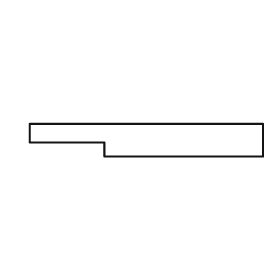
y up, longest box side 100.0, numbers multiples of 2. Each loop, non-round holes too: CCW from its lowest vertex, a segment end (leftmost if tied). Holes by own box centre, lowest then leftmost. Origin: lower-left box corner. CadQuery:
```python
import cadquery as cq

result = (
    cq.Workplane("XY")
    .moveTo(32.0, 0.0)
    .lineTo(100.0, 0.0)
    .lineTo(100.0, 14.0)
    .lineTo(0.0, 14.0)
    .lineTo(0.0, 6.0)
    .lineTo(32.0, 6.0)
    .close()
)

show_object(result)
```